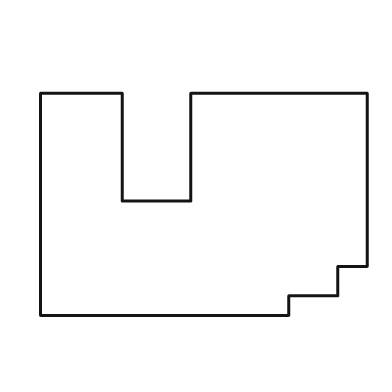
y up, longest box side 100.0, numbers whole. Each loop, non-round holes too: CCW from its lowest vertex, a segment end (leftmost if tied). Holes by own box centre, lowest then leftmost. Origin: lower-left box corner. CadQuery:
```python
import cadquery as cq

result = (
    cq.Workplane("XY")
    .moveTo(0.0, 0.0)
    .lineTo(76.0, 0.0)
    .lineTo(76.0, 6.0)
    .lineTo(91.0, 6.0)
    .lineTo(91.0, 15.0)
    .lineTo(100.0, 15.0)
    .lineTo(100.0, 68.0)
    .lineTo(46.0, 68.0)
    .lineTo(46.0, 35.0)
    .lineTo(25.0, 35.0)
    .lineTo(25.0, 68.0)
    .lineTo(0.0, 68.0)
    .close()
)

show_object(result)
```